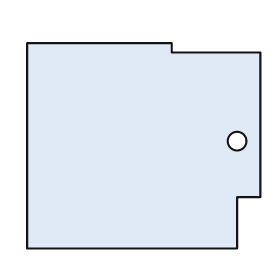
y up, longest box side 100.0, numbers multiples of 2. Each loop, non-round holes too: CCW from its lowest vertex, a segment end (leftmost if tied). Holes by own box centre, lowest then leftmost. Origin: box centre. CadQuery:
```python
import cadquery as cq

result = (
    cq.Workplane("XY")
    .moveTo(-50.0, -44.0)
    .lineTo(40.0, -44.0)
    .lineTo(40.0, -22.0)
    .lineTo(50.0, -22.0)
    .lineTo(50.0, 40.0)
    .lineTo(12.0, 40.0)
    .lineTo(12.0, 44.0)
    .lineTo(-50.0, 44.0)
    .close()
    .moveTo(40.0, 2.0)
    .circle(4.0)
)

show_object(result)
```